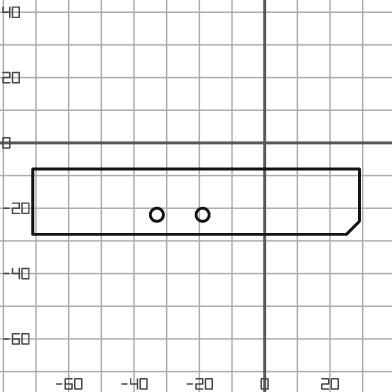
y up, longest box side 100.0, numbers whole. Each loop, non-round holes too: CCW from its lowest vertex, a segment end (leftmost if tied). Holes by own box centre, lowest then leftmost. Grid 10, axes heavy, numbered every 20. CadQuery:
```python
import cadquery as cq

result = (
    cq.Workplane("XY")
    .moveTo(-71.0, -28.0)
    .lineTo(25.0, -28.0)
    .lineTo(29.0, -24.0)
    .lineTo(29.0, -8.0)
    .lineTo(-71.0, -8.0)
    .close()
    .moveTo(-33.0, -22.0)
    .circle(2.0)
    .moveTo(-19.0, -22.0)
    .circle(2.0)
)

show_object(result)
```